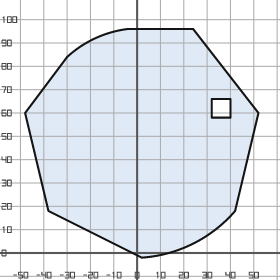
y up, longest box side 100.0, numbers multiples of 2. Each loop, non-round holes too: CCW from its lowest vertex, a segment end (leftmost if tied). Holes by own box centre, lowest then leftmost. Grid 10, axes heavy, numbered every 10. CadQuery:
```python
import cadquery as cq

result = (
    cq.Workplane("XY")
    .moveTo(2.0, -2.0)
    .threePointArc((24.0, 4.0), (42.0, 18.0))
    .lineTo(52.0, 60.0)
    .lineTo(24.0, 96.0)
    .lineTo(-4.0, 96.0)
    .threePointArc((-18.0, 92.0), (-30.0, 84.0))
    .lineTo(-48.0, 60.0)
    .lineTo(-38.0, 18.0)
    .close()
    .moveTo(32.0, 58.0)
    .lineTo(40.0, 58.0)
    .lineTo(40.0, 66.0)
    .lineTo(32.0, 66.0)
    .close()
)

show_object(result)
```